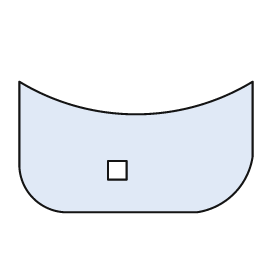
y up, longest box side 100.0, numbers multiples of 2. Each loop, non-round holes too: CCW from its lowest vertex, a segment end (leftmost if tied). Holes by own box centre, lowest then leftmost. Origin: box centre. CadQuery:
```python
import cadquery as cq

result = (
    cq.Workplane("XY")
    .moveTo(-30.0, -28.0)
    .lineTo(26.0, -28.0)
    .threePointArc((42.0, -20.0), (50.0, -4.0))
    .lineTo(50.0, 28.0)
    .threePointArc((0.0, 14.0), (-50.0, 28.0))
    .lineTo(-50.0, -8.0)
    .threePointArc((-44.0, -22.0), (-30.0, -28.0))
    .close()
    .moveTo(-12.0, -14.0)
    .lineTo(-4.0, -14.0)
    .lineTo(-4.0, -6.0)
    .lineTo(-12.0, -6.0)
    .close()
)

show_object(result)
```